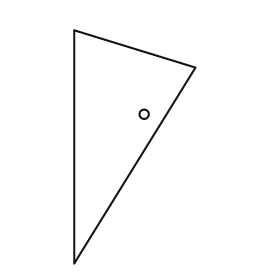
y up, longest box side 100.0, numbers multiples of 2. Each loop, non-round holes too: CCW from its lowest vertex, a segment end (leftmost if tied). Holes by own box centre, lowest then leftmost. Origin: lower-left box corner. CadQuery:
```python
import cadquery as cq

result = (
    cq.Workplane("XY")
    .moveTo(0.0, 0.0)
    .lineTo(52.0, 84.0)
    .lineTo(0.0, 100.0)
    .close()
    .moveTo(30.0, 64.0)
    .circle(2.0)
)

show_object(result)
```